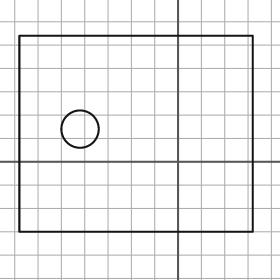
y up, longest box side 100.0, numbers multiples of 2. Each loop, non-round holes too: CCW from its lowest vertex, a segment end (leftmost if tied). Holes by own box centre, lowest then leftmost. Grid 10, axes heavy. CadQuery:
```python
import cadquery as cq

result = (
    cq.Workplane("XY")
    .moveTo(-68.0, -30.0)
    .lineTo(32.0, -30.0)
    .lineTo(32.0, 54.0)
    .lineTo(-68.0, 54.0)
    .close()
    .moveTo(-42.0, 14.0)
    .circle(8.0)
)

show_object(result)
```